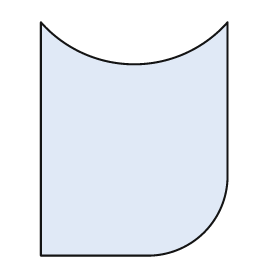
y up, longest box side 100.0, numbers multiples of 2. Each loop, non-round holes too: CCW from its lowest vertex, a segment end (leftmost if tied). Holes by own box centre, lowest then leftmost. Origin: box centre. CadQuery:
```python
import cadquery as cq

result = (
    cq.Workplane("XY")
    .moveTo(-40.0, -50.0)
    .lineTo(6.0, -50.0)
    .threePointArc((30.0, -40.0), (40.0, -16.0))
    .lineTo(40.0, 50.0)
    .threePointArc((0.0, 32.0), (-40.0, 50.0))
    .close()
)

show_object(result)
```